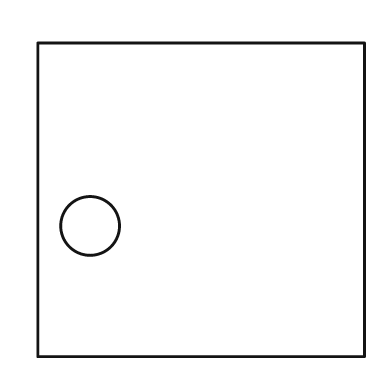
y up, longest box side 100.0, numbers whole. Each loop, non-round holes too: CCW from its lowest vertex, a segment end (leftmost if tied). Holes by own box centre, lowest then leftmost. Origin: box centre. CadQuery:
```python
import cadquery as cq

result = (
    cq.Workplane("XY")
    .moveTo(-50.0, -48.0)
    .lineTo(50.0, -48.0)
    .lineTo(50.0, 48.0)
    .lineTo(-50.0, 48.0)
    .close()
    .moveTo(-34.0, -8.0)
    .circle(9.0)
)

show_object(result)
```